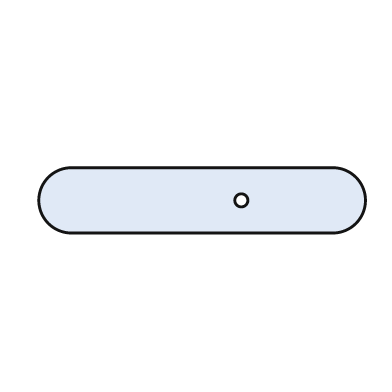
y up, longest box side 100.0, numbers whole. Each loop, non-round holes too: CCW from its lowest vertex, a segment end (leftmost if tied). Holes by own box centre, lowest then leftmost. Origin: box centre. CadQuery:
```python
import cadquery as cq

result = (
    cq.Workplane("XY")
    .moveTo(-40.0, -10.0)
    .lineTo(40.0, -10.0)
    .threePointArc((50.0, 0.0), (40.0, 10.0))
    .lineTo(-40.0, 10.0)
    .threePointArc((-50.0, 0.0), (-40.0, -10.0))
    .close()
    .moveTo(12.0, 0.0)
    .circle(2.0)
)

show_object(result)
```